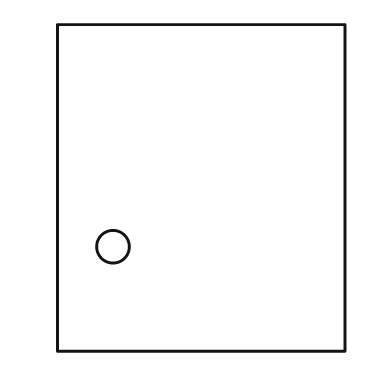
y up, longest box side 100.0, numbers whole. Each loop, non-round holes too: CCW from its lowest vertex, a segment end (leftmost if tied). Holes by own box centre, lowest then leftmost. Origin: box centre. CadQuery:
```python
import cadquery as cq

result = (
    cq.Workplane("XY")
    .moveTo(-44.0, -50.0)
    .lineTo(44.0, -50.0)
    .lineTo(44.0, 50.0)
    .lineTo(-44.0, 50.0)
    .close()
    .moveTo(-27.0, -18.0)
    .circle(5.0)
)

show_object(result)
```